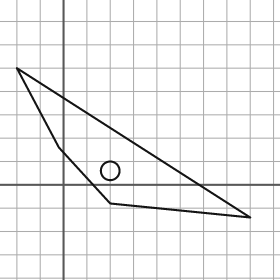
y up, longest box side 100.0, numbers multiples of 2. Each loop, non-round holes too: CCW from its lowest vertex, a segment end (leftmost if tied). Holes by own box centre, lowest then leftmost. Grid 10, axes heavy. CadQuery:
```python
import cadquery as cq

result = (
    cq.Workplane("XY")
    .moveTo(80.0, -14.0)
    .lineTo(-20.0, 50.0)
    .lineTo(-2.0, 16.0)
    .lineTo(20.0, -8.0)
    .close()
    .moveTo(20.0, 6.0)
    .circle(4.0)
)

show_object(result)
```